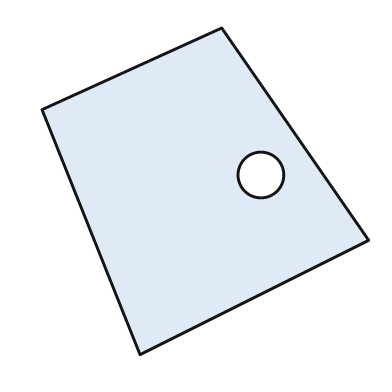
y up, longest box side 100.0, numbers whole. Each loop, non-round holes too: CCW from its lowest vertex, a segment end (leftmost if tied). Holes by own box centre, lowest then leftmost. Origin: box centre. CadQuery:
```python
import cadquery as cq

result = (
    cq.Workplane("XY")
    .moveTo(-20.0, -50.0)
    .lineTo(50.0, -15.0)
    .lineTo(5.0, 50.0)
    .lineTo(-50.0, 25.0)
    .close()
    .moveTo(17.0, 5.0)
    .circle(7.0)
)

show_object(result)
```